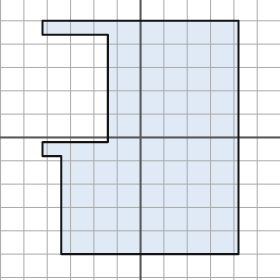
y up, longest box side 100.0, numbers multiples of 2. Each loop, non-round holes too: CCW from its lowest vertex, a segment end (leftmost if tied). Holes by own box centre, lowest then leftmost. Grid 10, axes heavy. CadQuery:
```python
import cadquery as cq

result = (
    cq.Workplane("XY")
    .moveTo(-34.0, -50.0)
    .lineTo(42.0, -50.0)
    .lineTo(42.0, 50.0)
    .lineTo(-42.0, 50.0)
    .lineTo(-42.0, 44.0)
    .lineTo(-14.0, 44.0)
    .lineTo(-14.0, -2.0)
    .lineTo(-42.0, -2.0)
    .lineTo(-42.0, -8.0)
    .lineTo(-34.0, -8.0)
    .close()
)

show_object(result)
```